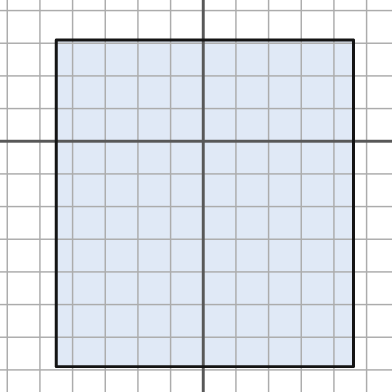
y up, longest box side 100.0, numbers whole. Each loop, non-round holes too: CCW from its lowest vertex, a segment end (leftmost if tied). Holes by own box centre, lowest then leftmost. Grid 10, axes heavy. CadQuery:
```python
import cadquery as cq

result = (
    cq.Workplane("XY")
    .moveTo(-45.0, -69.0)
    .lineTo(46.0, -69.0)
    .lineTo(46.0, 31.0)
    .lineTo(-45.0, 31.0)
    .close()
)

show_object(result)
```